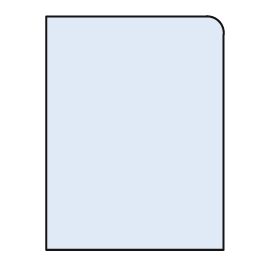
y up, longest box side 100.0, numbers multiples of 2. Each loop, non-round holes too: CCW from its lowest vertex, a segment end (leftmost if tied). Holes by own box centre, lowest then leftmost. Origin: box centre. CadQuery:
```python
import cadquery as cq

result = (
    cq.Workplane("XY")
    .moveTo(-38.0, -50.0)
    .lineTo(38.0, -50.0)
    .lineTo(38.0, 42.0)
    .threePointArc((36.0, 48.0), (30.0, 50.0))
    .lineTo(-38.0, 50.0)
    .close()
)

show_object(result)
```